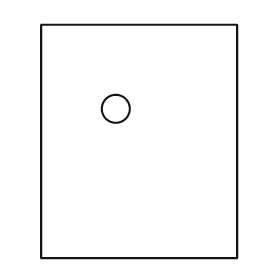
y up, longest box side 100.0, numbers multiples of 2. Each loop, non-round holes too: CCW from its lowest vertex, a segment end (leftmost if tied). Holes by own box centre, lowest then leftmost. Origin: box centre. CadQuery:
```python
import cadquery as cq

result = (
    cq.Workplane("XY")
    .moveTo(-42.0, -50.0)
    .lineTo(42.0, -50.0)
    .lineTo(42.0, 50.0)
    .lineTo(-42.0, 50.0)
    .close()
    .moveTo(-10.0, 14.0)
    .circle(6.0)
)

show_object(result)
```